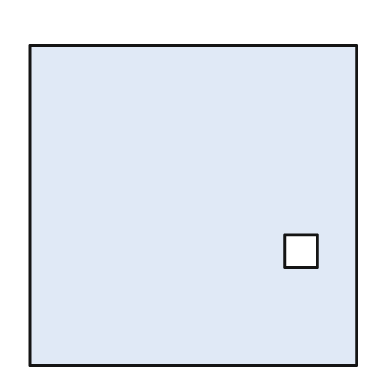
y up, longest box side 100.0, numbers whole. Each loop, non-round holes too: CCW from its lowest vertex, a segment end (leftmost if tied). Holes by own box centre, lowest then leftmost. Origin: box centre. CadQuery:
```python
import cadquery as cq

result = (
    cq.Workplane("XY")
    .moveTo(-50.0, -49.0)
    .lineTo(50.0, -49.0)
    .lineTo(50.0, 49.0)
    .lineTo(-50.0, 49.0)
    .close()
    .moveTo(28.0, -19.0)
    .lineTo(38.0, -19.0)
    .lineTo(38.0, -9.0)
    .lineTo(28.0, -9.0)
    .close()
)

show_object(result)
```